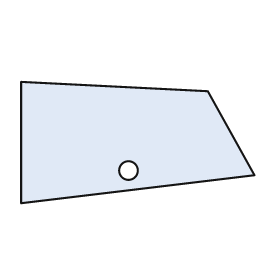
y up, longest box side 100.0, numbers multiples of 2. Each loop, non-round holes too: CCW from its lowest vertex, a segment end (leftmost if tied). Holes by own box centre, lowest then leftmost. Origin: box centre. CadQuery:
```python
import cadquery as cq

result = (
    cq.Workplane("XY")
    .moveTo(-50.0, -26.0)
    .lineTo(50.0, -14.0)
    .lineTo(30.0, 22.0)
    .lineTo(-50.0, 26.0)
    .close()
    .moveTo(-4.0, -12.0)
    .circle(4.0)
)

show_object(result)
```